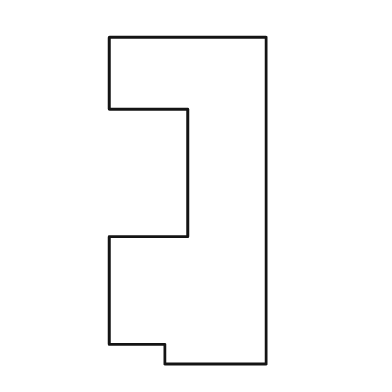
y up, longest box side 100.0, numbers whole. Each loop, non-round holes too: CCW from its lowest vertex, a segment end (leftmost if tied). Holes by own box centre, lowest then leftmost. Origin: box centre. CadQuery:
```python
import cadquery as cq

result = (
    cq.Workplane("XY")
    .moveTo(-7.0, -50.0)
    .lineTo(24.0, -50.0)
    .lineTo(24.0, 50.0)
    .lineTo(-24.0, 50.0)
    .lineTo(-24.0, 28.0)
    .lineTo(0.0, 28.0)
    .lineTo(0.0, -11.0)
    .lineTo(-24.0, -11.0)
    .lineTo(-24.0, -44.0)
    .lineTo(-7.0, -44.0)
    .close()
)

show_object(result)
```